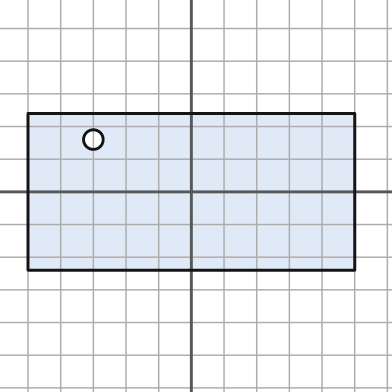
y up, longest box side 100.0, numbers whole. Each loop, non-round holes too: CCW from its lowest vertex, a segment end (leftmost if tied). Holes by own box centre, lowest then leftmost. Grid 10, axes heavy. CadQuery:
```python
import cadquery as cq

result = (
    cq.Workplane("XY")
    .moveTo(-50.0, -24.0)
    .lineTo(50.0, -24.0)
    .lineTo(50.0, 24.0)
    .lineTo(-50.0, 24.0)
    .close()
    .moveTo(-30.0, 16.0)
    .circle(3.0)
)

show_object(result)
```